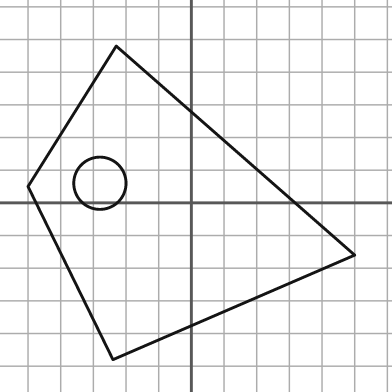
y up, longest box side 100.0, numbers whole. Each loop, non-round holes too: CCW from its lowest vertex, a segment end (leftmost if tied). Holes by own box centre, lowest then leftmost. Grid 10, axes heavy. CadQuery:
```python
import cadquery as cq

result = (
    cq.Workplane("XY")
    .moveTo(-24.0, -48.0)
    .lineTo(50.0, -16.0)
    .lineTo(-23.0, 48.0)
    .lineTo(-50.0, 5.0)
    .close()
    .moveTo(-28.0, 6.0)
    .circle(8.0)
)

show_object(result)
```